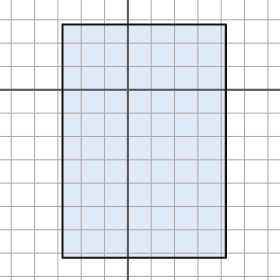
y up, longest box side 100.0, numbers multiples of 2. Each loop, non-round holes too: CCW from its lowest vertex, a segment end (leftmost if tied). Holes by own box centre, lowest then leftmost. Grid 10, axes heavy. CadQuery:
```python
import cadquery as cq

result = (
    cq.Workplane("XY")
    .moveTo(-28.0, -72.0)
    .lineTo(42.0, -72.0)
    .lineTo(42.0, 28.0)
    .lineTo(-28.0, 28.0)
    .close()
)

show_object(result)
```